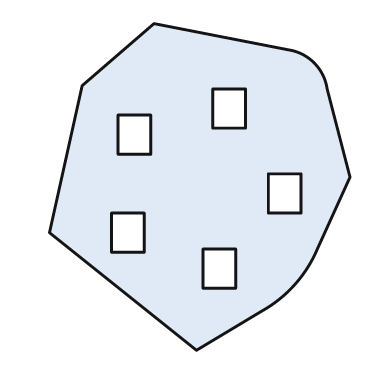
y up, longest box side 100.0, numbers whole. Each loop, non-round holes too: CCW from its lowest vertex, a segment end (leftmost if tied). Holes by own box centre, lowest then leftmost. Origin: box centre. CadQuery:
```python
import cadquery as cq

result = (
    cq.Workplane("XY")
    .moveTo(-1.0, -50.0)
    .lineTo(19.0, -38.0)
    .threePointArc((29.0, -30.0), (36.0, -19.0))
    .lineTo(46.0, 3.0)
    .lineTo(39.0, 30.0)
    .threePointArc((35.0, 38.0), (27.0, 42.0))
    .lineTo(-14.0, 50.0)
    .lineTo(-36.0, 31.0)
    .lineTo(-46.0, -14.0)
    .close()
    .moveTo(1.0, -31.0)
    .lineTo(11.0, -31.0)
    .lineTo(11.0, -19.0)
    .lineTo(1.0, -19.0)
    .close()
    .moveTo(-27.0, -20.0)
    .lineTo(-17.0, -20.0)
    .lineTo(-17.0, -8.0)
    .lineTo(-27.0, -8.0)
    .close()
    .moveTo(21.0, -8.0)
    .lineTo(31.0, -8.0)
    .lineTo(31.0, 4.0)
    .lineTo(21.0, 4.0)
    .close()
    .moveTo(-25.0, 10.0)
    .lineTo(-15.0, 10.0)
    .lineTo(-15.0, 22.0)
    .lineTo(-25.0, 22.0)
    .close()
    .moveTo(4.0, 18.0)
    .lineTo(14.0, 18.0)
    .lineTo(14.0, 30.0)
    .lineTo(4.0, 30.0)
    .close()
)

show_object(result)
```